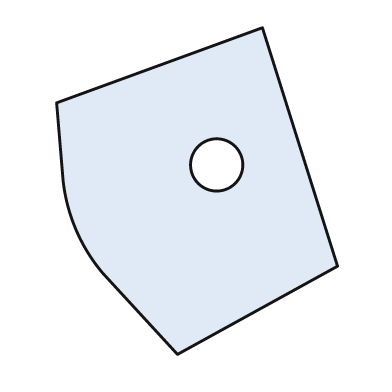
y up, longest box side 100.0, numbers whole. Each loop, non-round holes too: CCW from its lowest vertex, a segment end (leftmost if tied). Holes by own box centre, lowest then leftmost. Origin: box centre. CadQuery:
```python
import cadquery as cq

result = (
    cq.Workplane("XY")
    .moveTo(-6.0, -50.0)
    .lineTo(43.0, -23.0)
    .lineTo(20.0, 50.0)
    .lineTo(-43.0, 27.0)
    .lineTo(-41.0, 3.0)
    .threePointArc((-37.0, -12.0), (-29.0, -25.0))
    .close()
    .moveTo(6.0, 8.0)
    .circle(8.0)
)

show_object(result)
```